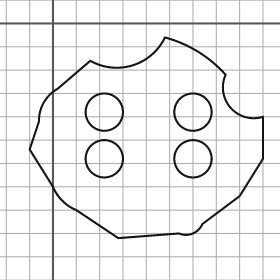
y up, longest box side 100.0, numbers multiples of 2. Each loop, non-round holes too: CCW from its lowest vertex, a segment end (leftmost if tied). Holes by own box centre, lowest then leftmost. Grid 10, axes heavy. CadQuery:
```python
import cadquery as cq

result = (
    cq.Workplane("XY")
    .moveTo(28.0, -92.0)
    .lineTo(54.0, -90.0)
    .threePointArc((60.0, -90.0), (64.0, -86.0))
    .lineTo(80.0, -74.0)
    .lineTo(90.0, -58.0)
    .lineTo(90.0, -40.0)
    .threePointArc((76.0, -36.0), (74.0, -22.0))
    .threePointArc((62.0, -12.0), (48.0, -6.0))
    .threePointArc((34.0, -18.0), (16.0, -16.0))
    .lineTo(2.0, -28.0)
    .threePointArc((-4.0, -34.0), (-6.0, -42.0))
    .lineTo(-10.0, -54.0)
    .lineTo(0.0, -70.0)
    .threePointArc((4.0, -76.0), (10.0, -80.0))
    .close()
    .moveTo(22.0, -58.0)
    .circle(8.0)
    .moveTo(60.0, -58.0)
    .circle(8.0)
    .moveTo(22.0, -38.0)
    .circle(8.0)
    .moveTo(60.0, -38.0)
    .circle(8.0)
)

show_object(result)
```